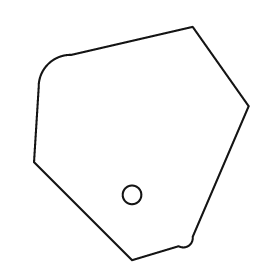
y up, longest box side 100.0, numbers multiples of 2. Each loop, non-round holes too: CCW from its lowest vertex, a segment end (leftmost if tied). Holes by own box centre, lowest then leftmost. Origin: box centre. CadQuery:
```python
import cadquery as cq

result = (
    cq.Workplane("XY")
    .moveTo(-4.0, -50.0)
    .lineTo(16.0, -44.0)
    .threePointArc((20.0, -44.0), (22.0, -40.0))
    .lineTo(46.0, 16.0)
    .lineTo(22.0, 50.0)
    .lineTo(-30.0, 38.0)
    .threePointArc((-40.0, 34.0), (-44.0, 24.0))
    .lineTo(-46.0, -8.0)
    .close()
    .moveTo(-4.0, -22.0)
    .circle(4.0)
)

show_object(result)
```